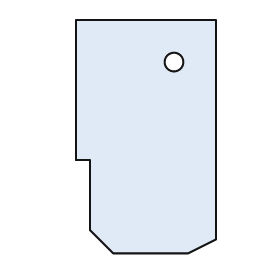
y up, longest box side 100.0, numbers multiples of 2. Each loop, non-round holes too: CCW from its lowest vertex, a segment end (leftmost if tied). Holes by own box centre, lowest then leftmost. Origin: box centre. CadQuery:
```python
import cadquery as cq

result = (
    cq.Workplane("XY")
    .moveTo(-14.0, -50.0)
    .lineTo(18.0, -50.0)
    .lineTo(30.0, -44.0)
    .lineTo(30.0, 50.0)
    .lineTo(-30.0, 50.0)
    .lineTo(-30.0, -10.0)
    .lineTo(-24.0, -10.0)
    .lineTo(-24.0, -40.0)
    .close()
    .moveTo(12.0, 32.0)
    .circle(4.0)
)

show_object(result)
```